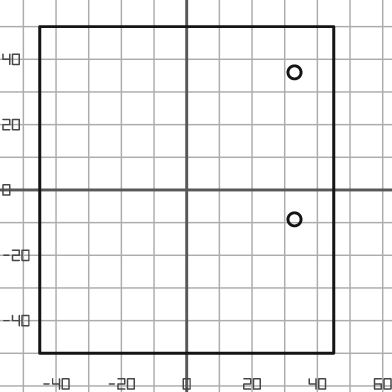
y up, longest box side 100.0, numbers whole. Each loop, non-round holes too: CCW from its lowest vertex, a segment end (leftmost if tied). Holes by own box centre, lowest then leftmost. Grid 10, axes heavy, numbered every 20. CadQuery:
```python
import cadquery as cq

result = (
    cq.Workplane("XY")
    .moveTo(-45.0, -50.0)
    .lineTo(45.0, -50.0)
    .lineTo(45.0, 50.0)
    .lineTo(-45.0, 50.0)
    .close()
    .moveTo(33.0, -9.0)
    .circle(2.0)
    .moveTo(33.0, 36.0)
    .circle(2.0)
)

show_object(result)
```